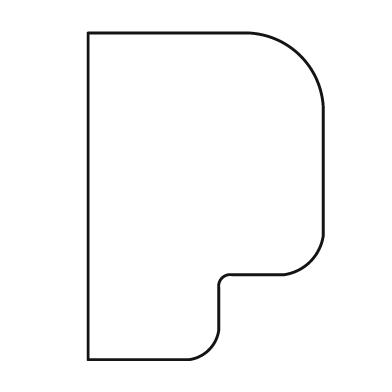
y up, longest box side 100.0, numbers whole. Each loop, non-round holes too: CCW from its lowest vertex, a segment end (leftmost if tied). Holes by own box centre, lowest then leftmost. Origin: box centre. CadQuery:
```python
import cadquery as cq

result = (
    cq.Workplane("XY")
    .moveTo(-36.0, -50.0)
    .lineTo(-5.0, -50.0)
    .threePointArc((1.0, -47.0), (4.0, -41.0))
    .lineTo(4.0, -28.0)
    .threePointArc((5.0, -25.0), (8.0, -24.0))
    .lineTo(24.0, -24.0)
    .threePointArc((32.0, -20.0), (36.0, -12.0))
    .lineTo(36.0, 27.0)
    .threePointArc((29.0, 43.0), (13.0, 50.0))
    .lineTo(-36.0, 50.0)
    .close()
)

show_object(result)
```